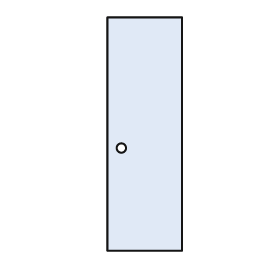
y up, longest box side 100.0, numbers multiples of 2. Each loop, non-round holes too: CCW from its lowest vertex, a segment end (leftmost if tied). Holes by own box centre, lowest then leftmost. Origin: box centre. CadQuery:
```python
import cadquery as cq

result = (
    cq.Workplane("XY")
    .moveTo(-16.0, -50.0)
    .lineTo(16.0, -50.0)
    .lineTo(16.0, 50.0)
    .lineTo(-16.0, 50.0)
    .close()
    .moveTo(-10.0, -6.0)
    .circle(2.0)
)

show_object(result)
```